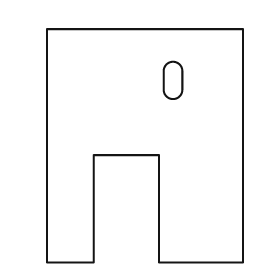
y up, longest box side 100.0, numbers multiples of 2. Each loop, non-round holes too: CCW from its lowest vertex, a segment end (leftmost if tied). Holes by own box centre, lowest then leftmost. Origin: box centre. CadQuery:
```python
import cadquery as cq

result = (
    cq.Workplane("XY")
    .moveTo(-42.0, -50.0)
    .lineTo(-22.0, -50.0)
    .lineTo(-22.0, -4.0)
    .lineTo(6.0, -4.0)
    .lineTo(6.0, -50.0)
    .lineTo(42.0, -50.0)
    .lineTo(42.0, 50.0)
    .lineTo(-42.0, 50.0)
    .close()
    .moveTo(8.0, 24.0)
    .threePointArc((12.0, 20.0), (16.0, 24.0))
    .lineTo(16.0, 32.0)
    .threePointArc((12.0, 36.0), (8.0, 32.0))
    .close()
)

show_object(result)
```